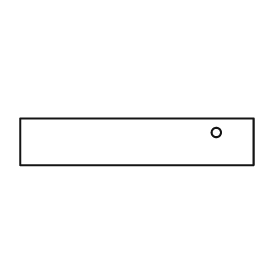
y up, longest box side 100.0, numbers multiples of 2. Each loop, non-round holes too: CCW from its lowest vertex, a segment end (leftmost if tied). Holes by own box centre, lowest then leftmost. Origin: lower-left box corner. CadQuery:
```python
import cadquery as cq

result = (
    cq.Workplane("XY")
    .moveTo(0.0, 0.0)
    .lineTo(100.0, 0.0)
    .lineTo(100.0, 20.0)
    .lineTo(0.0, 20.0)
    .close()
    .moveTo(84.0, 14.0)
    .circle(2.0)
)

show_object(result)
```